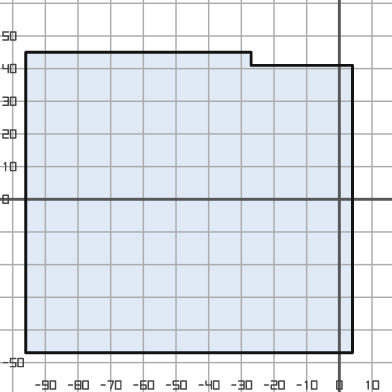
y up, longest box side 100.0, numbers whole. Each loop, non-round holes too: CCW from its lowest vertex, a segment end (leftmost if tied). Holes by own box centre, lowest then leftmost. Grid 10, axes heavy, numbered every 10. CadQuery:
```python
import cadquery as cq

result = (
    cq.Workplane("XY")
    .moveTo(-96.0, -47.0)
    .lineTo(4.0, -47.0)
    .lineTo(4.0, 41.0)
    .lineTo(-27.0, 41.0)
    .lineTo(-27.0, 45.0)
    .lineTo(-96.0, 45.0)
    .close()
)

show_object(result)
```